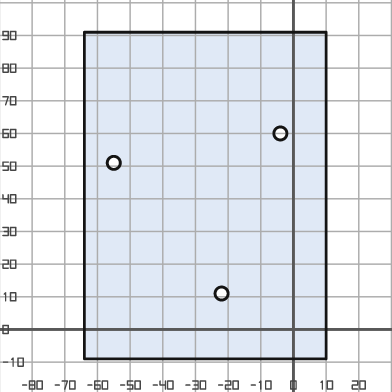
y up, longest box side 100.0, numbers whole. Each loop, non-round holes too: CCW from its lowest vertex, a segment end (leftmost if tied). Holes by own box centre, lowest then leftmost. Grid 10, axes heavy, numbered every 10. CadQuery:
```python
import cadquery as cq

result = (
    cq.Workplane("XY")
    .moveTo(-64.0, -9.0)
    .lineTo(10.0, -9.0)
    .lineTo(10.0, 91.0)
    .lineTo(-64.0, 91.0)
    .close()
    .moveTo(-22.0, 11.0)
    .circle(2.0)
    .moveTo(-55.0, 51.0)
    .circle(2.0)
    .moveTo(-4.0, 60.0)
    .circle(2.0)
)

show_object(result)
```